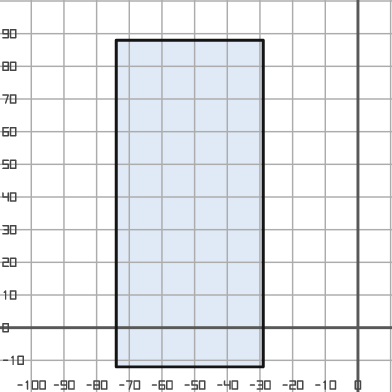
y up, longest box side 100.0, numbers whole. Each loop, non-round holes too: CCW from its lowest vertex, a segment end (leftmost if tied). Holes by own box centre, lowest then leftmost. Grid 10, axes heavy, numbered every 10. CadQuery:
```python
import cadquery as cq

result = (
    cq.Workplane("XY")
    .moveTo(-74.0, -12.0)
    .lineTo(-29.0, -12.0)
    .lineTo(-29.0, 88.0)
    .lineTo(-74.0, 88.0)
    .close()
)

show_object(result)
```